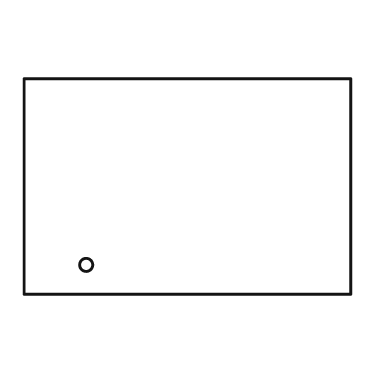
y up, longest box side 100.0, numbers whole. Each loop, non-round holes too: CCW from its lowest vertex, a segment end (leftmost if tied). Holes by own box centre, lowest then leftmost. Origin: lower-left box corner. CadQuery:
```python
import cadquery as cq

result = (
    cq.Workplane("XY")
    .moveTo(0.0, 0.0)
    .lineTo(100.0, 0.0)
    .lineTo(100.0, 66.0)
    .lineTo(0.0, 66.0)
    .close()
    .moveTo(19.0, 9.0)
    .circle(2.0)
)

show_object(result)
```